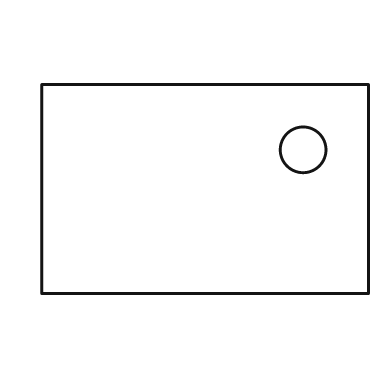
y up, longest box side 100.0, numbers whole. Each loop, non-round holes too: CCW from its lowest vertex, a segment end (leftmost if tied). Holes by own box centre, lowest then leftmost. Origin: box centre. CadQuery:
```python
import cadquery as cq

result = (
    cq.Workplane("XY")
    .moveTo(-50.0, -32.0)
    .lineTo(50.0, -32.0)
    .lineTo(50.0, 32.0)
    .lineTo(-50.0, 32.0)
    .close()
    .moveTo(30.0, 12.0)
    .circle(7.0)
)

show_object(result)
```